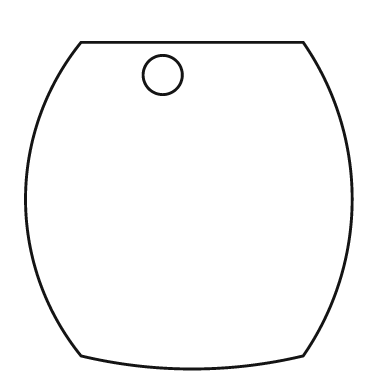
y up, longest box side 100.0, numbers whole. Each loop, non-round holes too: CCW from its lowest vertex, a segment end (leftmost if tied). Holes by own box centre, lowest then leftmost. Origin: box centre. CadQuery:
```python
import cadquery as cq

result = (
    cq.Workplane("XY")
    .moveTo(-33.0, -46.0)
    .threePointArc((1.0, -50.0), (35.0, -46.0))
    .threePointArc((50.0, 2.0), (35.0, 50.0))
    .lineTo(-33.0, 50.0)
    .threePointArc((-50.0, 2.0), (-33.0, -46.0))
    .close()
    .moveTo(-8.0, 40.0)
    .circle(6.0)
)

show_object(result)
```